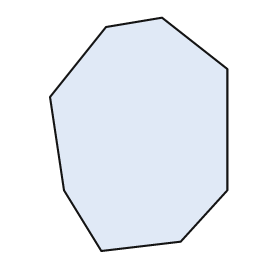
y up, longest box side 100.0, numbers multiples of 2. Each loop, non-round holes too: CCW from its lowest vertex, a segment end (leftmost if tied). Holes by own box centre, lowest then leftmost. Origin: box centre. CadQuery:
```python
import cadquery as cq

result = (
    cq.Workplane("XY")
    .moveTo(-16.0, -50.0)
    .lineTo(18.0, -46.0)
    .lineTo(38.0, -24.0)
    .lineTo(38.0, 28.0)
    .lineTo(10.0, 50.0)
    .lineTo(-14.0, 46.0)
    .lineTo(-38.0, 16.0)
    .lineTo(-32.0, -24.0)
    .close()
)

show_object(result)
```